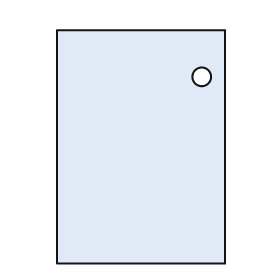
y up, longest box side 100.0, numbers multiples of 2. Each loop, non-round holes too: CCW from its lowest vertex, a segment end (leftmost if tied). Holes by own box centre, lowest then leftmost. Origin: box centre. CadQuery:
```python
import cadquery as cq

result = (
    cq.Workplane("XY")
    .moveTo(-36.0, -50.0)
    .lineTo(36.0, -50.0)
    .lineTo(36.0, 50.0)
    .lineTo(-36.0, 50.0)
    .close()
    .moveTo(26.0, 30.0)
    .circle(4.0)
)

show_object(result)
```